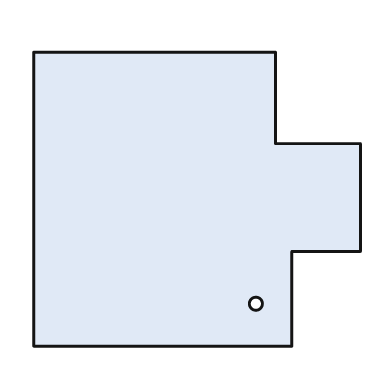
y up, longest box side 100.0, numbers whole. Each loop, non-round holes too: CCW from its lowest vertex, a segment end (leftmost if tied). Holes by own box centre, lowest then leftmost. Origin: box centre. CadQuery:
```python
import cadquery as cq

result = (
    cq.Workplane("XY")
    .moveTo(-50.0, -45.0)
    .lineTo(29.0, -45.0)
    .lineTo(29.0, -16.0)
    .lineTo(50.0, -16.0)
    .lineTo(50.0, 17.0)
    .lineTo(24.0, 17.0)
    .lineTo(24.0, 45.0)
    .lineTo(-50.0, 45.0)
    .close()
    .moveTo(18.0, -32.0)
    .circle(2.0)
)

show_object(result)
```